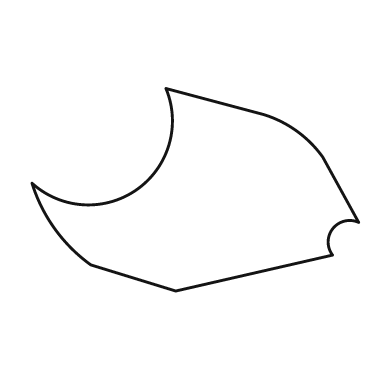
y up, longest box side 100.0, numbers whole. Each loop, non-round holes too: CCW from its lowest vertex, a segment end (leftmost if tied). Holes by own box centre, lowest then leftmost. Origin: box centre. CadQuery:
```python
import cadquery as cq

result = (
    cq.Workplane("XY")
    .moveTo(-6.0, -31.0)
    .lineTo(42.0, -20.0)
    .threePointArc((42.0, -12.0), (50.0, -10.0))
    .lineTo(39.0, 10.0)
    .threePointArc((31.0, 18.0), (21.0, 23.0))
    .lineTo(-9.0, 31.0)
    .threePointArc((-18.0, 0.0), (-50.0, 2.0))
    .threePointArc((-43.0, -12.0), (-32.0, -23.0))
    .close()
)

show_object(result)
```